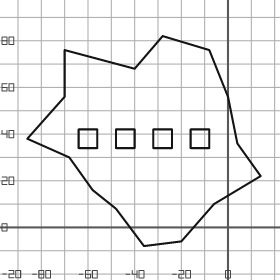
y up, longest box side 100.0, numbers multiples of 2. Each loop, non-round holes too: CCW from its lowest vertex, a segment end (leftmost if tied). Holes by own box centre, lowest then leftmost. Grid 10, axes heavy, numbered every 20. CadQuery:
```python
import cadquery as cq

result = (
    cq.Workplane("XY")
    .moveTo(-36.0, -8.0)
    .lineTo(-20.0, -6.0)
    .lineTo(-6.0, 10.0)
    .lineTo(14.0, 22.0)
    .lineTo(4.0, 36.0)
    .lineTo(0.0, 56.0)
    .lineTo(-8.0, 76.0)
    .lineTo(-28.0, 82.0)
    .lineTo(-40.0, 68.0)
    .lineTo(-70.0, 76.0)
    .lineTo(-70.0, 56.0)
    .lineTo(-86.0, 38.0)
    .lineTo(-68.0, 30.0)
    .lineTo(-58.0, 16.0)
    .lineTo(-48.0, 8.0)
    .close()
    .moveTo(-64.0, 34.0)
    .lineTo(-56.0, 34.0)
    .lineTo(-56.0, 42.0)
    .lineTo(-64.0, 42.0)
    .close()
    .moveTo(-48.0, 34.0)
    .lineTo(-40.0, 34.0)
    .lineTo(-40.0, 42.0)
    .lineTo(-48.0, 42.0)
    .close()
    .moveTo(-32.0, 34.0)
    .lineTo(-24.0, 34.0)
    .lineTo(-24.0, 42.0)
    .lineTo(-32.0, 42.0)
    .close()
    .moveTo(-16.0, 34.0)
    .lineTo(-8.0, 34.0)
    .lineTo(-8.0, 42.0)
    .lineTo(-16.0, 42.0)
    .close()
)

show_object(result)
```